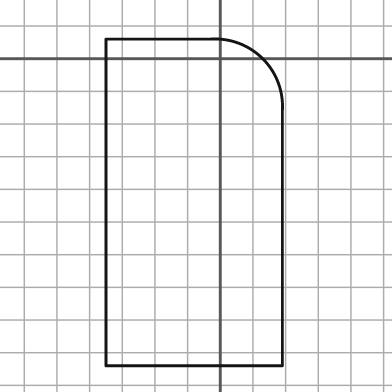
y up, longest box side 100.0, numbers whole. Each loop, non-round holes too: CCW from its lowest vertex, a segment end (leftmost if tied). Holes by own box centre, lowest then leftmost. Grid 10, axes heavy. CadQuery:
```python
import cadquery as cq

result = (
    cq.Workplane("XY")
    .moveTo(-35.0, -94.0)
    .lineTo(19.0, -94.0)
    .lineTo(19.0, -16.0)
    .threePointArc((13.0, 0.0), (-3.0, 6.0))
    .lineTo(-35.0, 6.0)
    .close()
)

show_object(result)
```